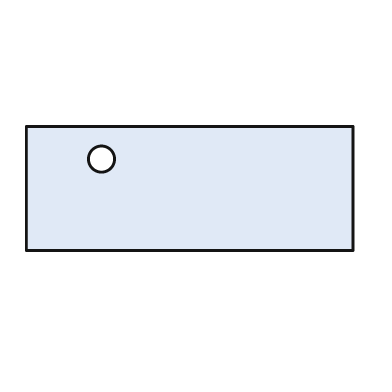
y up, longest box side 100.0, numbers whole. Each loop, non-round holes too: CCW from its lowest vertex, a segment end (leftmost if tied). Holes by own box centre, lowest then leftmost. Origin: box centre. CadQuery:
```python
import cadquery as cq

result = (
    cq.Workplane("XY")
    .moveTo(-50.0, -19.0)
    .lineTo(50.0, -19.0)
    .lineTo(50.0, 19.0)
    .lineTo(-50.0, 19.0)
    .close()
    .moveTo(-27.0, 9.0)
    .circle(4.0)
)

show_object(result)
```